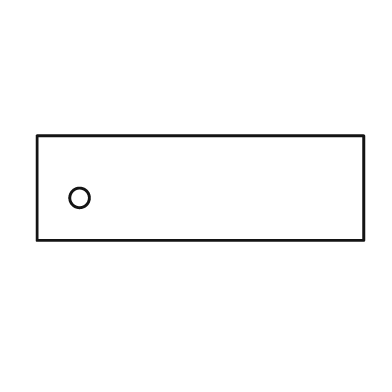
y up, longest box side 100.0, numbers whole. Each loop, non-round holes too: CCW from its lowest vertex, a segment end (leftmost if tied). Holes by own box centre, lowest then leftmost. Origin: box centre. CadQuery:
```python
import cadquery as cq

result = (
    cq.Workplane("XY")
    .moveTo(-50.0, -16.0)
    .lineTo(50.0, -16.0)
    .lineTo(50.0, 16.0)
    .lineTo(-50.0, 16.0)
    .close()
    .moveTo(-37.0, -3.0)
    .circle(3.0)
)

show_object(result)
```